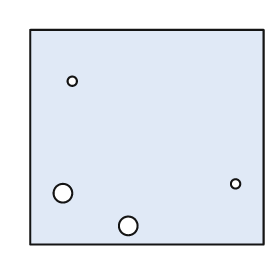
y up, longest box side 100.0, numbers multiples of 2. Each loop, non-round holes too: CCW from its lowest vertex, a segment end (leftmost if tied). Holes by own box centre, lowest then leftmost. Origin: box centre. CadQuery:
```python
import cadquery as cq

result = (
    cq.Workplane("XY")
    .moveTo(-50.0, -46.0)
    .lineTo(50.0, -46.0)
    .lineTo(50.0, 46.0)
    .lineTo(-50.0, 46.0)
    .close()
    .moveTo(-8.0, -38.0)
    .circle(4.0)
    .moveTo(-36.0, -24.0)
    .circle(4.0)
    .moveTo(38.0, -20.0)
    .circle(2.0)
    .moveTo(-32.0, 24.0)
    .circle(2.0)
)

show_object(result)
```